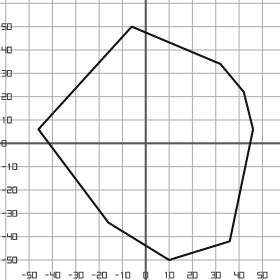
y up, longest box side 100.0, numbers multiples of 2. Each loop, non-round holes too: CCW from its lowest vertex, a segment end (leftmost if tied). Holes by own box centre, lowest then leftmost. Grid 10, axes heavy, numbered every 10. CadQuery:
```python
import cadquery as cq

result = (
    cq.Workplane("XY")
    .moveTo(10.0, -50.0)
    .lineTo(36.0, -42.0)
    .lineTo(46.0, 6.0)
    .lineTo(42.0, 22.0)
    .lineTo(32.0, 34.0)
    .lineTo(-6.0, 50.0)
    .lineTo(-46.0, 6.0)
    .lineTo(-16.0, -34.0)
    .close()
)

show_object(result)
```